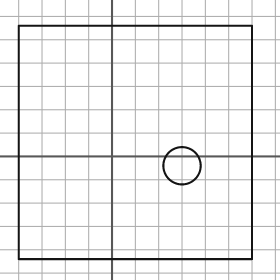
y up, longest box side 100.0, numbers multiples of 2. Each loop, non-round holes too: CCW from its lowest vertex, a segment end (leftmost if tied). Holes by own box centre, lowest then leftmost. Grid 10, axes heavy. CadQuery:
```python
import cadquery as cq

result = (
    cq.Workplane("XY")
    .moveTo(-40.0, -44.0)
    .lineTo(60.0, -44.0)
    .lineTo(60.0, 56.0)
    .lineTo(-40.0, 56.0)
    .close()
    .moveTo(30.0, -4.0)
    .circle(8.0)
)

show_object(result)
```